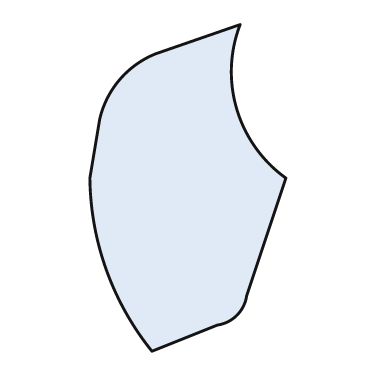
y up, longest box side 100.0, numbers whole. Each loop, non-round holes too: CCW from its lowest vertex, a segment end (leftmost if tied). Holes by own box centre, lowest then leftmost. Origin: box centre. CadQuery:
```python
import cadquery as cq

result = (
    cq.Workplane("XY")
    .moveTo(-11.0, -50.0)
    .lineTo(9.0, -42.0)
    .threePointArc((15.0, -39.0), (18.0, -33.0))
    .lineTo(30.0, 3.0)
    .threePointArc((15.0, 24.0), (16.0, 50.0))
    .lineTo(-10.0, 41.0)
    .threePointArc((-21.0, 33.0), (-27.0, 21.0))
    .lineTo(-30.0, 3.0)
    .threePointArc((-25.0, -25.0), (-11.0, -50.0))
    .close()
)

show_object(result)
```